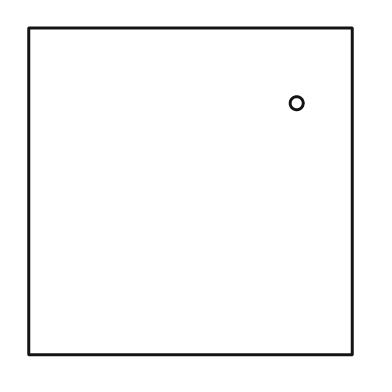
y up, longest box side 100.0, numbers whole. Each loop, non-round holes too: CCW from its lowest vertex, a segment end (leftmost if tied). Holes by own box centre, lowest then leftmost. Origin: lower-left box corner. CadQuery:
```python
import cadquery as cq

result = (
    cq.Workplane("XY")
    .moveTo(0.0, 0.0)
    .lineTo(99.0, 0.0)
    .lineTo(99.0, 100.0)
    .lineTo(0.0, 100.0)
    .close()
    .moveTo(82.0, 77.0)
    .circle(2.0)
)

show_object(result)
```